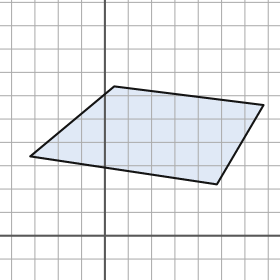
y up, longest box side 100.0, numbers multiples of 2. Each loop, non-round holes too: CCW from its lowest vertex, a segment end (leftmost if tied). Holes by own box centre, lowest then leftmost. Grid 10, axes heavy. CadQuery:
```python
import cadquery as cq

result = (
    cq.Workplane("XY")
    .moveTo(48.0, 22.0)
    .lineTo(68.0, 56.0)
    .lineTo(4.0, 64.0)
    .lineTo(-32.0, 34.0)
    .close()
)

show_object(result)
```